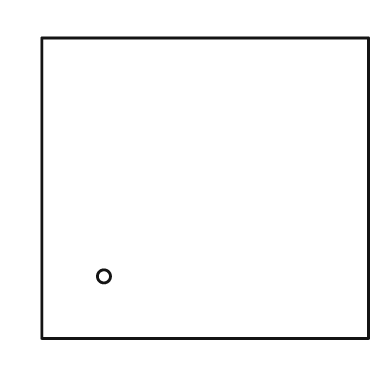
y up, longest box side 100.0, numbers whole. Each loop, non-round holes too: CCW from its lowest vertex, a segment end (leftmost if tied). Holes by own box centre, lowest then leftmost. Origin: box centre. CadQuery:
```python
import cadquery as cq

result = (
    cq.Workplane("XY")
    .moveTo(-50.0, -46.0)
    .lineTo(50.0, -46.0)
    .lineTo(50.0, 46.0)
    .lineTo(-50.0, 46.0)
    .close()
    .moveTo(-31.0, -27.0)
    .circle(2.0)
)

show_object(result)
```